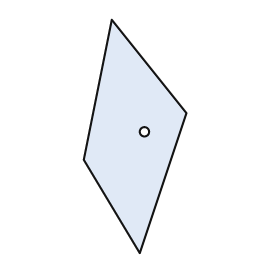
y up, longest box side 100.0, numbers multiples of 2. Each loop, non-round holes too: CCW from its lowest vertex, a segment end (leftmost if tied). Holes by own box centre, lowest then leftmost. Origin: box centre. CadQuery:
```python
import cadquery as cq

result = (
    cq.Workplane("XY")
    .moveTo(2.0, -50.0)
    .lineTo(22.0, 10.0)
    .lineTo(-10.0, 50.0)
    .lineTo(-22.0, -10.0)
    .close()
    .moveTo(4.0, 2.0)
    .circle(2.0)
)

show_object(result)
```